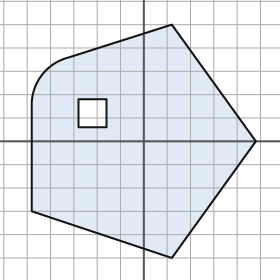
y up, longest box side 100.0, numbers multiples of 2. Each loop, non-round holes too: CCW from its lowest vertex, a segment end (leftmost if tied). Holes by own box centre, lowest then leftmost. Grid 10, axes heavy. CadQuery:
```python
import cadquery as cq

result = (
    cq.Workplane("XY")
    .moveTo(12.0, -50.0)
    .lineTo(48.0, 0.0)
    .lineTo(12.0, 50.0)
    .lineTo(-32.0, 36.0)
    .threePointArc((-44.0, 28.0), (-48.0, 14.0))
    .lineTo(-48.0, -30.0)
    .close()
    .moveTo(-28.0, 6.0)
    .lineTo(-16.0, 6.0)
    .lineTo(-16.0, 18.0)
    .lineTo(-28.0, 18.0)
    .close()
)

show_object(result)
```